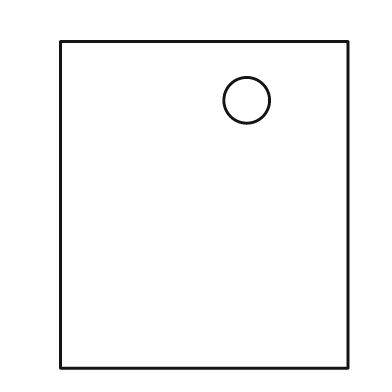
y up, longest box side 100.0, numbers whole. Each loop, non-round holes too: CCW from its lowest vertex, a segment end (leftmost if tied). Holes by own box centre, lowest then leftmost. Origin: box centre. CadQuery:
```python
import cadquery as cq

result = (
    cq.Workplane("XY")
    .moveTo(-44.0, -50.0)
    .lineTo(44.0, -50.0)
    .lineTo(44.0, 50.0)
    .lineTo(-44.0, 50.0)
    .close()
    .moveTo(13.0, 32.0)
    .circle(7.0)
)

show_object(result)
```